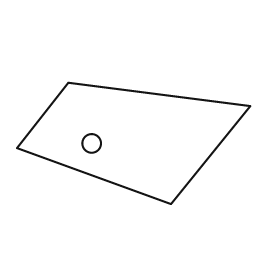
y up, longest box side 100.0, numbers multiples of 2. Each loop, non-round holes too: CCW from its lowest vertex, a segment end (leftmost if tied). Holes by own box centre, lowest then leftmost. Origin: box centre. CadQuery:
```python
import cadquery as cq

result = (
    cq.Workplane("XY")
    .moveTo(16.0, -26.0)
    .lineTo(50.0, 16.0)
    .lineTo(-28.0, 26.0)
    .lineTo(-50.0, -2.0)
    .close()
    .moveTo(-18.0, 0.0)
    .circle(4.0)
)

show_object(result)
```